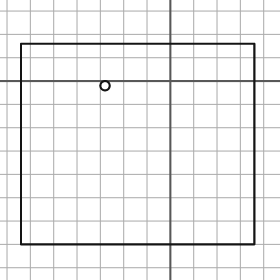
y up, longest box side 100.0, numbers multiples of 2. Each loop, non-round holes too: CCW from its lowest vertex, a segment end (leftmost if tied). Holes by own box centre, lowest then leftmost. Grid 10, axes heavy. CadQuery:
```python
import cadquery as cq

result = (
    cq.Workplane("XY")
    .moveTo(-64.0, -70.0)
    .lineTo(36.0, -70.0)
    .lineTo(36.0, 16.0)
    .lineTo(-64.0, 16.0)
    .close()
    .moveTo(-28.0, -2.0)
    .circle(2.0)
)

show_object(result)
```